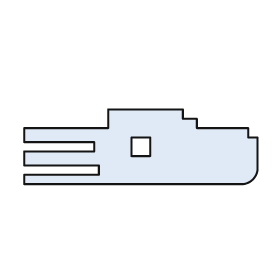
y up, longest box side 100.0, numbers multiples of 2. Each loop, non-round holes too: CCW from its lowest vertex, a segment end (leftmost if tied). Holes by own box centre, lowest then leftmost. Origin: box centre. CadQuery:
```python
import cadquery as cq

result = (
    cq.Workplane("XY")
    .moveTo(-50.0, -16.0)
    .lineTo(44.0, -16.0)
    .threePointArc((48.0, -14.0), (50.0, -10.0))
    .lineTo(50.0, 4.0)
    .lineTo(46.0, 4.0)
    .lineTo(46.0, 8.0)
    .lineTo(24.0, 8.0)
    .lineTo(24.0, 12.0)
    .lineTo(18.0, 12.0)
    .lineTo(18.0, 16.0)
    .lineTo(-14.0, 16.0)
    .lineTo(-14.0, 8.0)
    .lineTo(-50.0, 8.0)
    .lineTo(-50.0, 2.0)
    .lineTo(-20.0, 2.0)
    .lineTo(-20.0, -2.0)
    .lineTo(-50.0, -2.0)
    .lineTo(-50.0, -8.0)
    .lineTo(-18.0, -8.0)
    .lineTo(-18.0, -12.0)
    .lineTo(-50.0, -12.0)
    .close()
    .moveTo(-4.0, -4.0)
    .lineTo(4.0, -4.0)
    .lineTo(4.0, 4.0)
    .lineTo(-4.0, 4.0)
    .close()
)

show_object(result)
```